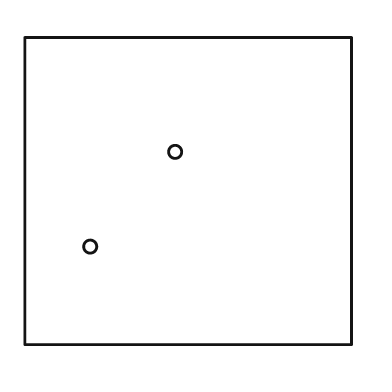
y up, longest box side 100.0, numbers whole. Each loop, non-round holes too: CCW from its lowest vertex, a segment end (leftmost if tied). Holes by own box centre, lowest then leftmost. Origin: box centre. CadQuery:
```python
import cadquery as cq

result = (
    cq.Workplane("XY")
    .moveTo(-50.0, -47.0)
    .lineTo(50.0, -47.0)
    .lineTo(50.0, 47.0)
    .lineTo(-50.0, 47.0)
    .close()
    .moveTo(-30.0, -17.0)
    .circle(2.0)
    .moveTo(-4.0, 12.0)
    .circle(2.0)
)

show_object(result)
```